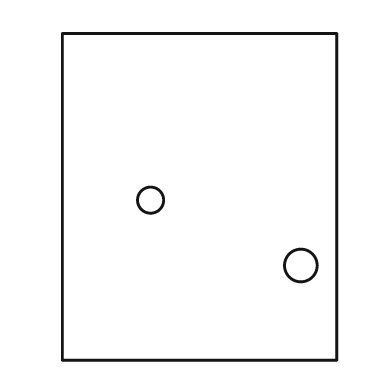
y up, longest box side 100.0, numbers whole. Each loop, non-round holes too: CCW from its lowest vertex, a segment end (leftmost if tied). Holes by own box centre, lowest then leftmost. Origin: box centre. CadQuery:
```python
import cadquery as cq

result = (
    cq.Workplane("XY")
    .moveTo(-42.0, -50.0)
    .lineTo(42.0, -50.0)
    .lineTo(42.0, 50.0)
    .lineTo(-42.0, 50.0)
    .close()
    .moveTo(31.0, -21.0)
    .circle(5.0)
    .moveTo(-15.0, -1.0)
    .circle(4.0)
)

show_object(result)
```